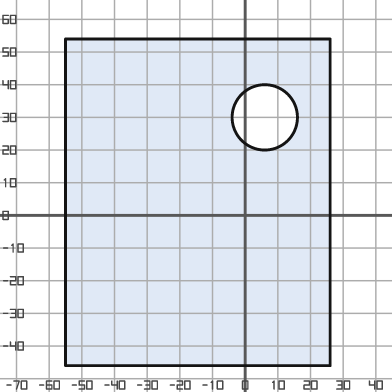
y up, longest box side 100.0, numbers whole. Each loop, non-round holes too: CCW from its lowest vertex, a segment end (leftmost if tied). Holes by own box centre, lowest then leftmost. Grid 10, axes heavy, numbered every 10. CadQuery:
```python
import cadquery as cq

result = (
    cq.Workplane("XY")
    .moveTo(-55.0, -46.0)
    .lineTo(26.0, -46.0)
    .lineTo(26.0, 54.0)
    .lineTo(-55.0, 54.0)
    .close()
    .moveTo(6.0, 30.0)
    .circle(10.0)
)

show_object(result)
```